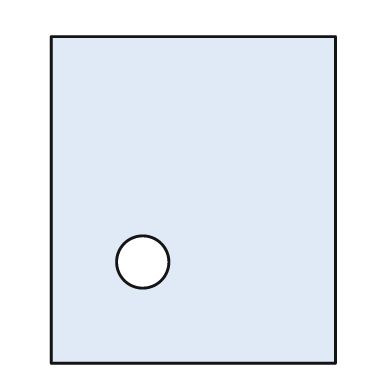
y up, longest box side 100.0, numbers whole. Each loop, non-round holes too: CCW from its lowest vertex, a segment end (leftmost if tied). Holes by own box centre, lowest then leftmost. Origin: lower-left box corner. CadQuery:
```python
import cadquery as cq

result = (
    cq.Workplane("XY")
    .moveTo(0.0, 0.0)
    .lineTo(87.0, 0.0)
    .lineTo(87.0, 100.0)
    .lineTo(0.0, 100.0)
    .close()
    .moveTo(28.0, 31.0)
    .circle(8.0)
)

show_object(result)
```